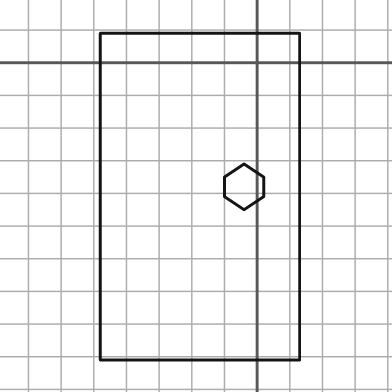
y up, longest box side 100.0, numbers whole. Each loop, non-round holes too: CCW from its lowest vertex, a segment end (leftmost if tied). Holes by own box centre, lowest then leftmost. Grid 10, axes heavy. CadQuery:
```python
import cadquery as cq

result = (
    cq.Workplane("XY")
    .moveTo(-48.0, -91.0)
    .lineTo(13.0, -91.0)
    .lineTo(13.0, 9.0)
    .lineTo(-48.0, 9.0)
    .close()
    .moveTo(-4.0, -45.0)
    .lineTo(2.0, -41.0)
    .lineTo(2.0, -35.0)
    .lineTo(-4.0, -31.0)
    .lineTo(-10.0, -35.0)
    .lineTo(-10.0, -41.0)
    .close()
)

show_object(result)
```